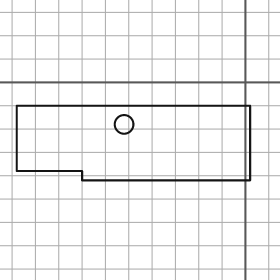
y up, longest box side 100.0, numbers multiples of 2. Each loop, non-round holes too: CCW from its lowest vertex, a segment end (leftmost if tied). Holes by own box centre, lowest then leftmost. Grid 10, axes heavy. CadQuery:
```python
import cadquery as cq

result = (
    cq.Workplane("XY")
    .moveTo(-70.0, -42.0)
    .lineTo(2.0, -42.0)
    .lineTo(2.0, -10.0)
    .lineTo(-98.0, -10.0)
    .lineTo(-98.0, -38.0)
    .lineTo(-70.0, -38.0)
    .close()
    .moveTo(-52.0, -18.0)
    .circle(4.0)
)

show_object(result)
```